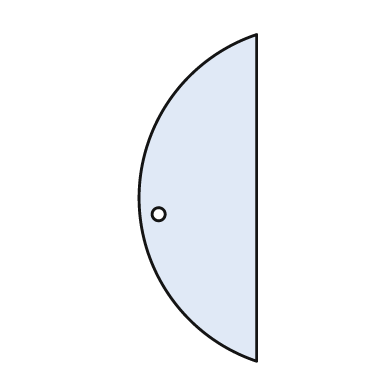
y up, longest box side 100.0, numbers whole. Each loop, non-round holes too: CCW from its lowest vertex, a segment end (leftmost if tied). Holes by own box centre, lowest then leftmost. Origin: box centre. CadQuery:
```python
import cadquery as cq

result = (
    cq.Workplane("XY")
    .moveTo(18.0, -50.0)
    .lineTo(18.0, 50.0)
    .threePointArc((-18.0, 0.0), (18.0, -50.0))
    .close()
    .moveTo(-12.0, -5.0)
    .circle(2.0)
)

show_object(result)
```